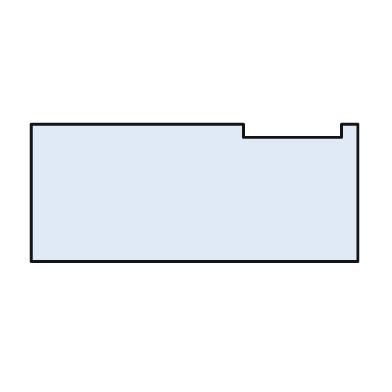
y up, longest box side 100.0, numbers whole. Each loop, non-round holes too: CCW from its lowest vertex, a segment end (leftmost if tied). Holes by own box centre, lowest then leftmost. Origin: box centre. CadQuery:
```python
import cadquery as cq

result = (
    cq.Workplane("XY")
    .moveTo(-50.0, -21.0)
    .lineTo(50.0, -21.0)
    .lineTo(50.0, 21.0)
    .lineTo(45.0, 21.0)
    .lineTo(45.0, 17.0)
    .lineTo(15.0, 17.0)
    .lineTo(15.0, 21.0)
    .lineTo(-50.0, 21.0)
    .close()
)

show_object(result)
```